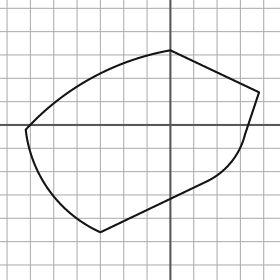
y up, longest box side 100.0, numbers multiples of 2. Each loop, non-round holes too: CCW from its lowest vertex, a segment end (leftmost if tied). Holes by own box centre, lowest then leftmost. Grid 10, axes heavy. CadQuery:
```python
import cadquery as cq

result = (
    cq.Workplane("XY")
    .moveTo(-30.0, -46.0)
    .lineTo(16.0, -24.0)
    .threePointArc((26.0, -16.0), (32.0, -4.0))
    .lineTo(38.0, 14.0)
    .lineTo(0.0, 32.0)
    .threePointArc((-34.0, 20.0), (-62.0, -2.0))
    .threePointArc((-52.0, -28.0), (-30.0, -46.0))
    .close()
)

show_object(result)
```